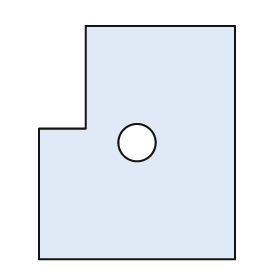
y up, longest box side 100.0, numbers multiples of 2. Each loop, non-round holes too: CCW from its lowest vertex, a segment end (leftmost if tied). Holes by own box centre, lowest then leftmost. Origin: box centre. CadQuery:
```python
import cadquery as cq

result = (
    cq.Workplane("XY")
    .moveTo(-42.0, -50.0)
    .lineTo(42.0, -50.0)
    .lineTo(42.0, 50.0)
    .lineTo(-22.0, 50.0)
    .lineTo(-22.0, 6.0)
    .lineTo(-42.0, 6.0)
    .close()
    .moveTo(0.0, 0.0)
    .circle(8.0)
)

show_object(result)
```